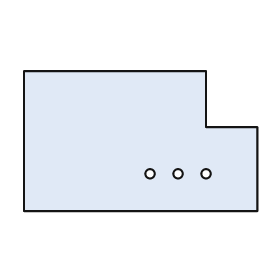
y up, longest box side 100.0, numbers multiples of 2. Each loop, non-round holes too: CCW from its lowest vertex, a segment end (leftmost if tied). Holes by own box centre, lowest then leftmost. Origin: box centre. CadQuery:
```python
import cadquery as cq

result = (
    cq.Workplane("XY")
    .moveTo(-50.0, -30.0)
    .lineTo(50.0, -30.0)
    .lineTo(50.0, 6.0)
    .lineTo(28.0, 6.0)
    .lineTo(28.0, 30.0)
    .lineTo(-50.0, 30.0)
    .close()
    .moveTo(4.0, -14.0)
    .circle(2.0)
    .moveTo(16.0, -14.0)
    .circle(2.0)
    .moveTo(28.0, -14.0)
    .circle(2.0)
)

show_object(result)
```